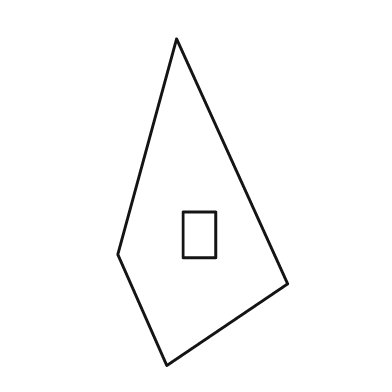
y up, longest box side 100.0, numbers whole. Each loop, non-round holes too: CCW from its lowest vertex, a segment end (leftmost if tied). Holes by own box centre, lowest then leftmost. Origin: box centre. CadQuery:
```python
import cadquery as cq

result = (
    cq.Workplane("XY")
    .moveTo(-11.0, -50.0)
    .lineTo(26.0, -25.0)
    .lineTo(-8.0, 50.0)
    .lineTo(-26.0, -16.0)
    .close()
    .moveTo(-6.0, -17.0)
    .lineTo(4.0, -17.0)
    .lineTo(4.0, -3.0)
    .lineTo(-6.0, -3.0)
    .close()
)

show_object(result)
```